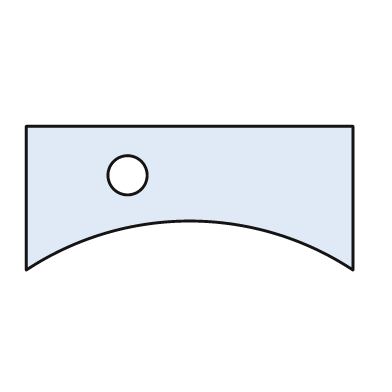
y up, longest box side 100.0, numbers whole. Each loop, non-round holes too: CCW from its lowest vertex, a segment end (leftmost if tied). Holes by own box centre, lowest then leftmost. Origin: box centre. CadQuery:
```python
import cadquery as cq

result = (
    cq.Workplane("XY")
    .moveTo(-50.0, -22.0)
    .threePointArc((0.0, -7.0), (50.0, -22.0))
    .lineTo(50.0, 22.0)
    .lineTo(-50.0, 22.0)
    .close()
    .moveTo(-19.0, 7.0)
    .circle(6.0)
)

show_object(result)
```